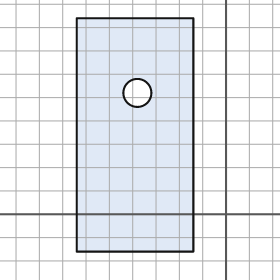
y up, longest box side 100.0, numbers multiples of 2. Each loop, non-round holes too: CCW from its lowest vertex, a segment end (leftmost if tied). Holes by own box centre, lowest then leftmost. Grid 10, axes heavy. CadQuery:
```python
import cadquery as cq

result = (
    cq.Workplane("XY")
    .moveTo(-64.0, -16.0)
    .lineTo(-14.0, -16.0)
    .lineTo(-14.0, 84.0)
    .lineTo(-64.0, 84.0)
    .close()
    .moveTo(-38.0, 52.0)
    .circle(6.0)
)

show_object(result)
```